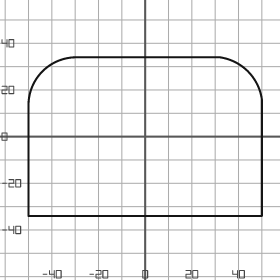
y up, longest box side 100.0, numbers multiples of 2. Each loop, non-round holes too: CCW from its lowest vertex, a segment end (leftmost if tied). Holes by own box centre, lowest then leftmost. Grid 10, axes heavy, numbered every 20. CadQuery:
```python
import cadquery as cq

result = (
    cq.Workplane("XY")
    .moveTo(-50.0, -34.0)
    .lineTo(50.0, -34.0)
    .lineTo(50.0, 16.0)
    .threePointArc((44.0, 28.0), (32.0, 34.0))
    .lineTo(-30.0, 34.0)
    .threePointArc((-44.0, 28.0), (-50.0, 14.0))
    .close()
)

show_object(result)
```